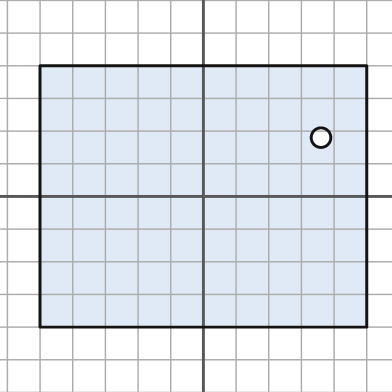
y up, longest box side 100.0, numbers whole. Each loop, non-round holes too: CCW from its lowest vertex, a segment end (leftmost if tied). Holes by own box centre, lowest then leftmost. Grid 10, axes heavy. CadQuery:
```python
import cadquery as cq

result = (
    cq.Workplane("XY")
    .moveTo(-50.0, -40.0)
    .lineTo(50.0, -40.0)
    .lineTo(50.0, 40.0)
    .lineTo(-50.0, 40.0)
    .close()
    .moveTo(36.0, 18.0)
    .circle(3.0)
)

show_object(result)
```